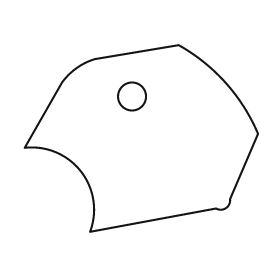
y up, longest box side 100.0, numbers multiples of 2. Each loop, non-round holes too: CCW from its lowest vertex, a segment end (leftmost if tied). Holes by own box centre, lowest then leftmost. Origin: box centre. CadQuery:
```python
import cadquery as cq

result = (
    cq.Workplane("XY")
    .moveTo(-22.0, -40.0)
    .lineTo(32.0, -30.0)
    .threePointArc((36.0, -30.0), (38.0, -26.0))
    .lineTo(50.0, 2.0)
    .threePointArc((36.0, 24.0), (16.0, 40.0))
    .lineTo(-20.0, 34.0)
    .threePointArc((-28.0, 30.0), (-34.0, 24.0))
    .lineTo(-50.0, -4.0)
    .threePointArc((-26.0, -14.0), (-22.0, -40.0))
    .close()
    .moveTo(-4.0, 18.0)
    .circle(6.0)
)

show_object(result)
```